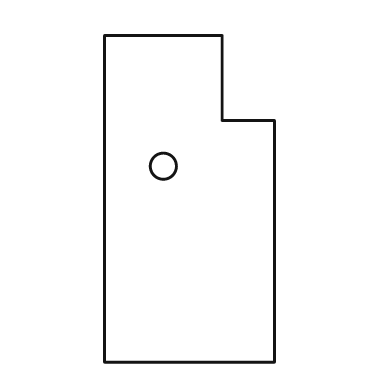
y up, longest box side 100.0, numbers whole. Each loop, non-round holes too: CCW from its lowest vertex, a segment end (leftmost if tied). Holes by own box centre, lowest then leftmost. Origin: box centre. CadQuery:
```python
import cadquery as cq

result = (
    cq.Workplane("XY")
    .moveTo(-26.0, -50.0)
    .lineTo(26.0, -50.0)
    .lineTo(26.0, 24.0)
    .lineTo(10.0, 24.0)
    .lineTo(10.0, 50.0)
    .lineTo(-26.0, 50.0)
    .close()
    .moveTo(-8.0, 10.0)
    .circle(4.0)
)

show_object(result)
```